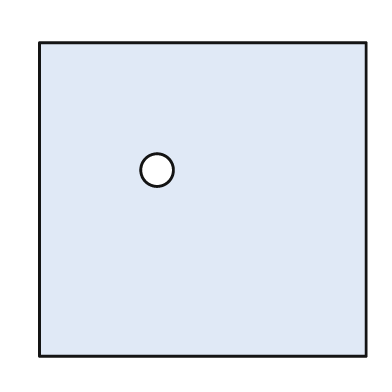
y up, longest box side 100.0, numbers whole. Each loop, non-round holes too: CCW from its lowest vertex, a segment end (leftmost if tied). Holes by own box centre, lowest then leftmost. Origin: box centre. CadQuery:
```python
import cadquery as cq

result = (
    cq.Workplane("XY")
    .moveTo(-50.0, -48.0)
    .lineTo(50.0, -48.0)
    .lineTo(50.0, 48.0)
    .lineTo(-50.0, 48.0)
    .close()
    .moveTo(-14.0, 9.0)
    .circle(5.0)
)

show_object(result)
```